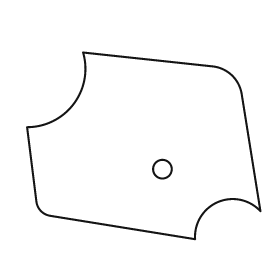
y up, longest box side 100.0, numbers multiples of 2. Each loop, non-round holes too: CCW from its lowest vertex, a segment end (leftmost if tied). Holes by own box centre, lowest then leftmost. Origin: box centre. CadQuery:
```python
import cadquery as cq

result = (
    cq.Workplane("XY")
    .moveTo(22.0, -40.0)
    .threePointArc((32.0, -24.0), (50.0, -28.0))
    .lineTo(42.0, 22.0)
    .threePointArc((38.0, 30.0), (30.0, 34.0))
    .lineTo(-26.0, 40.0)
    .threePointArc((-30.0, 18.0), (-50.0, 8.0))
    .lineTo(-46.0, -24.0)
    .threePointArc((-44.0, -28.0), (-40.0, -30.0))
    .close()
    .moveTo(8.0, -10.0)
    .circle(4.0)
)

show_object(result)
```